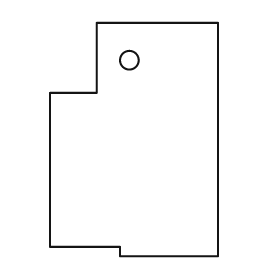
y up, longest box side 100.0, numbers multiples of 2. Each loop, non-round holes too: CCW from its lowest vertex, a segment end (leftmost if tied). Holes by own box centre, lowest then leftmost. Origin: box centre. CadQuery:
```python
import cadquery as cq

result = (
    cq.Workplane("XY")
    .moveTo(-6.0, -50.0)
    .lineTo(36.0, -50.0)
    .lineTo(36.0, 50.0)
    .lineTo(-16.0, 50.0)
    .lineTo(-16.0, 20.0)
    .lineTo(-36.0, 20.0)
    .lineTo(-36.0, -46.0)
    .lineTo(-6.0, -46.0)
    .close()
    .moveTo(-2.0, 34.0)
    .circle(4.0)
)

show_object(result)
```